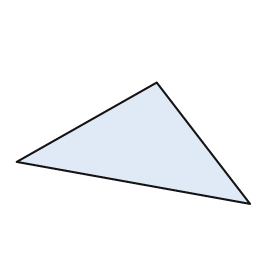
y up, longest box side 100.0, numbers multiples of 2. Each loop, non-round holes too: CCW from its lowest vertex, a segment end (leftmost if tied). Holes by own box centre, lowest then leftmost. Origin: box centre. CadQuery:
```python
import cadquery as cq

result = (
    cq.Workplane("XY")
    .moveTo(50.0, -26.0)
    .lineTo(10.0, 26.0)
    .lineTo(-50.0, -8.0)
    .close()
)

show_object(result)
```